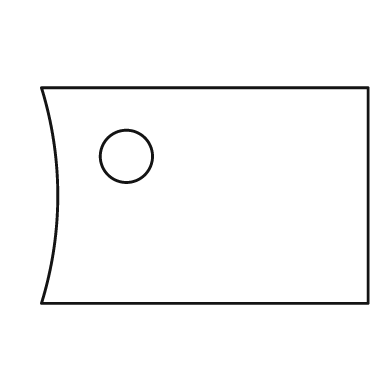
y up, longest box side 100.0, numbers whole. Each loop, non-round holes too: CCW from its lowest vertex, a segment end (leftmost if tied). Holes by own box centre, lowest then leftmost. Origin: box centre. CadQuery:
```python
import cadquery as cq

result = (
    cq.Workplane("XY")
    .moveTo(-50.0, -33.0)
    .lineTo(50.0, -33.0)
    .lineTo(50.0, 33.0)
    .lineTo(-50.0, 33.0)
    .threePointArc((-45.0, 0.0), (-50.0, -33.0))
    .close()
    .moveTo(-24.0, 12.0)
    .circle(8.0)
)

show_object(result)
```